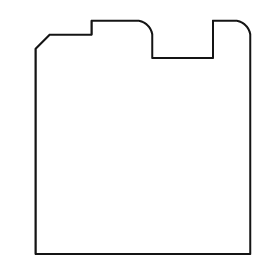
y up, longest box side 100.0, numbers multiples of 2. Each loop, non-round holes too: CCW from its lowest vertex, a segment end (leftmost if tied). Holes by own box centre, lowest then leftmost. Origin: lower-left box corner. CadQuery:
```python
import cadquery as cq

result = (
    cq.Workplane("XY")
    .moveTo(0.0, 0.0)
    .lineTo(92.0, 0.0)
    .lineTo(92.0, 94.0)
    .threePointArc((90.0, 98.0), (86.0, 100.0))
    .lineTo(76.0, 100.0)
    .lineTo(76.0, 84.0)
    .lineTo(50.0, 84.0)
    .lineTo(50.0, 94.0)
    .threePointArc((48.0, 98.0), (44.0, 100.0))
    .lineTo(24.0, 100.0)
    .lineTo(24.0, 94.0)
    .lineTo(6.0, 94.0)
    .lineTo(0.0, 88.0)
    .close()
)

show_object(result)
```